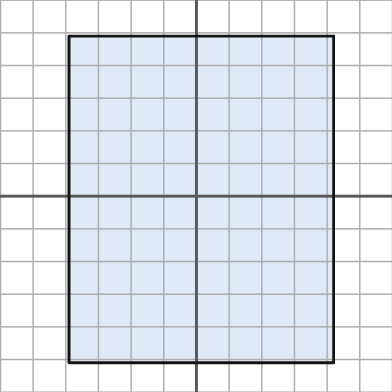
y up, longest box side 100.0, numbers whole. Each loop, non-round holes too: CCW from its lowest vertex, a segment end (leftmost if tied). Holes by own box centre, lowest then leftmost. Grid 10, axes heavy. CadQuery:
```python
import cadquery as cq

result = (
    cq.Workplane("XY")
    .moveTo(-39.0, -51.0)
    .lineTo(42.0, -51.0)
    .lineTo(42.0, 49.0)
    .lineTo(-39.0, 49.0)
    .close()
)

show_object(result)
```